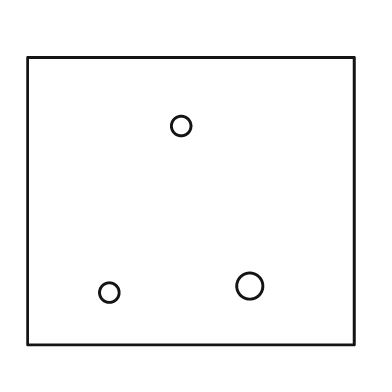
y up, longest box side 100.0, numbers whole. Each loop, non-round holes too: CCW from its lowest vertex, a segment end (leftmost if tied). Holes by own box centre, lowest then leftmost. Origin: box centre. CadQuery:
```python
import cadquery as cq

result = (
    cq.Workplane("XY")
    .moveTo(-50.0, -44.0)
    .lineTo(50.0, -44.0)
    .lineTo(50.0, 44.0)
    .lineTo(-50.0, 44.0)
    .close()
    .moveTo(-25.0, -28.0)
    .circle(3.0)
    .moveTo(18.0, -26.0)
    .circle(4.0)
    .moveTo(-3.0, 23.0)
    .circle(3.0)
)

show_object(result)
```